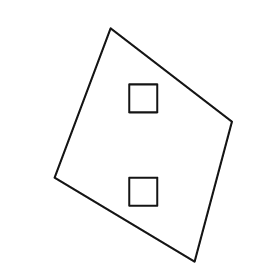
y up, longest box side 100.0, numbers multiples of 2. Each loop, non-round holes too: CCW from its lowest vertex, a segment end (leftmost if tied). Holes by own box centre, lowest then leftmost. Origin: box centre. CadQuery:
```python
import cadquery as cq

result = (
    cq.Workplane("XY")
    .moveTo(22.0, -50.0)
    .lineTo(38.0, 10.0)
    .lineTo(-14.0, 50.0)
    .lineTo(-38.0, -14.0)
    .close()
    .moveTo(-6.0, -26.0)
    .lineTo(6.0, -26.0)
    .lineTo(6.0, -14.0)
    .lineTo(-6.0, -14.0)
    .close()
    .moveTo(-6.0, 14.0)
    .lineTo(6.0, 14.0)
    .lineTo(6.0, 26.0)
    .lineTo(-6.0, 26.0)
    .close()
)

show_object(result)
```